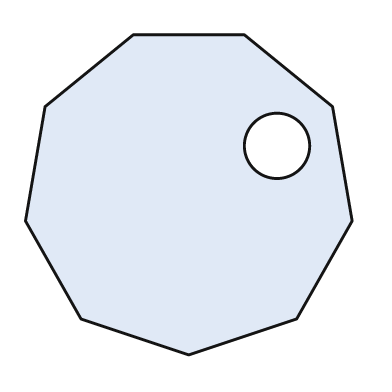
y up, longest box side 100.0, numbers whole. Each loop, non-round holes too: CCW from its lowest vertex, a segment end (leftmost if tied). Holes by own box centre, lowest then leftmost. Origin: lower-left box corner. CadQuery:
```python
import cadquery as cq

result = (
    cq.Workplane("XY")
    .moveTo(50.0, 0.0)
    .lineTo(83.0, 11.0)
    .lineTo(100.0, 41.0)
    .lineTo(94.0, 76.0)
    .lineTo(67.0, 98.0)
    .lineTo(33.0, 98.0)
    .lineTo(6.0, 76.0)
    .lineTo(0.0, 41.0)
    .lineTo(17.0, 11.0)
    .close()
    .moveTo(77.0, 64.0)
    .circle(10.0)
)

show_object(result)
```